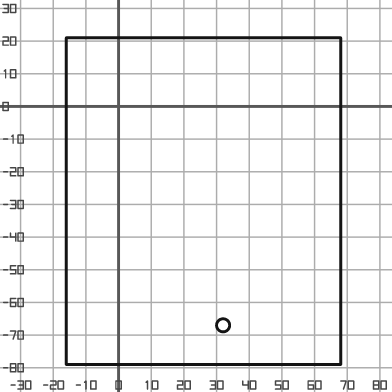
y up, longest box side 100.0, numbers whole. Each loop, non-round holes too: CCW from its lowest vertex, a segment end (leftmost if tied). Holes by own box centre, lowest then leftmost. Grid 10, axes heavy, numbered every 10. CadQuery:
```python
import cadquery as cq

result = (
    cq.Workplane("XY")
    .moveTo(-16.0, -79.0)
    .lineTo(68.0, -79.0)
    .lineTo(68.0, 21.0)
    .lineTo(-16.0, 21.0)
    .close()
    .moveTo(32.0, -67.0)
    .circle(2.0)
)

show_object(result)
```